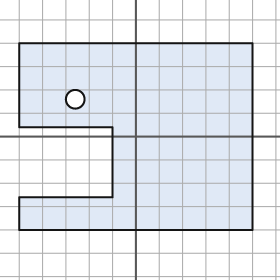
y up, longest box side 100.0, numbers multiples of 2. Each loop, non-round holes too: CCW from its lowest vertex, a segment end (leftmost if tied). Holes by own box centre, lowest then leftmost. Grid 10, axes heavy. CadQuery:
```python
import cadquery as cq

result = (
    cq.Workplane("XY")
    .moveTo(-50.0, -40.0)
    .lineTo(50.0, -40.0)
    .lineTo(50.0, 40.0)
    .lineTo(-50.0, 40.0)
    .lineTo(-50.0, 4.0)
    .lineTo(-10.0, 4.0)
    .lineTo(-10.0, -26.0)
    .lineTo(-50.0, -26.0)
    .close()
    .moveTo(-26.0, 16.0)
    .circle(4.0)
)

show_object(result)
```